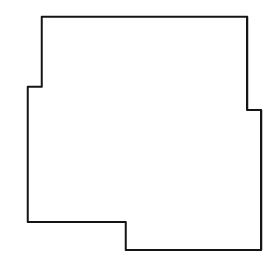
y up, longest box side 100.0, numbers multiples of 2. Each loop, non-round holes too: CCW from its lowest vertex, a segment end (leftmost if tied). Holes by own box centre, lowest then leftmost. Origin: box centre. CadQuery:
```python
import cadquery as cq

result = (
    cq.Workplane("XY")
    .moveTo(-8.0, -50.0)
    .lineTo(50.0, -50.0)
    .lineTo(50.0, 10.0)
    .lineTo(44.0, 10.0)
    .lineTo(44.0, 50.0)
    .lineTo(-44.0, 50.0)
    .lineTo(-44.0, 20.0)
    .lineTo(-50.0, 20.0)
    .lineTo(-50.0, -38.0)
    .lineTo(-8.0, -38.0)
    .close()
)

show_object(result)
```